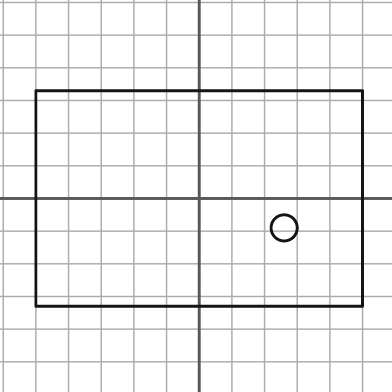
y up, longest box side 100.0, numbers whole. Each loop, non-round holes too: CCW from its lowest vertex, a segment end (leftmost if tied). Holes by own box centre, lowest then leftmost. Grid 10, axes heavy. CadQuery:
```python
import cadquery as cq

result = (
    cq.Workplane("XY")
    .moveTo(-50.0, -33.0)
    .lineTo(50.0, -33.0)
    .lineTo(50.0, 33.0)
    .lineTo(-50.0, 33.0)
    .close()
    .moveTo(26.0, -9.0)
    .circle(4.0)
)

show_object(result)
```